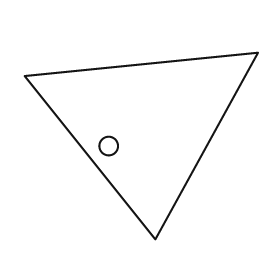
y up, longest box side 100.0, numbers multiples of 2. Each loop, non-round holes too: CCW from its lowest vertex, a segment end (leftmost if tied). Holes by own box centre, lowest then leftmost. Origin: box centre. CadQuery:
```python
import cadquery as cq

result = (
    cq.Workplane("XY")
    .moveTo(6.0, -40.0)
    .lineTo(50.0, 40.0)
    .lineTo(-50.0, 30.0)
    .close()
    .moveTo(-14.0, 0.0)
    .circle(4.0)
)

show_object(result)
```